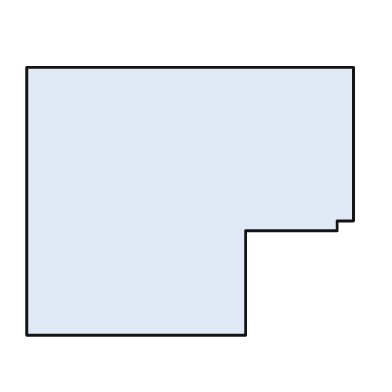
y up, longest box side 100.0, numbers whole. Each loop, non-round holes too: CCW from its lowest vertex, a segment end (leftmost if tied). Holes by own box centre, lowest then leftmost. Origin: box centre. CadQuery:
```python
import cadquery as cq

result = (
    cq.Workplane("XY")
    .moveTo(-50.0, -41.0)
    .lineTo(17.0, -41.0)
    .lineTo(17.0, -9.0)
    .lineTo(45.0, -9.0)
    .lineTo(45.0, -6.0)
    .lineTo(50.0, -6.0)
    .lineTo(50.0, 41.0)
    .lineTo(-50.0, 41.0)
    .close()
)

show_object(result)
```